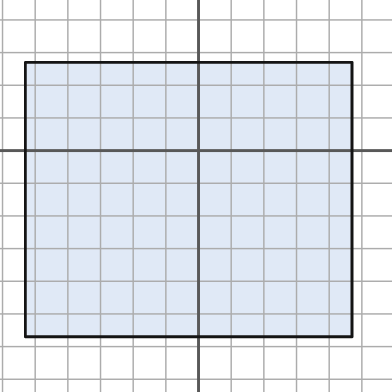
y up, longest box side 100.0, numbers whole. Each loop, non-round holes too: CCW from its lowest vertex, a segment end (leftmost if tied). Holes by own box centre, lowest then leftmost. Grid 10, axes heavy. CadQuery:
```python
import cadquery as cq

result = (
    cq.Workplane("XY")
    .moveTo(-53.0, -57.0)
    .lineTo(47.0, -57.0)
    .lineTo(47.0, 27.0)
    .lineTo(-53.0, 27.0)
    .close()
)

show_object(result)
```